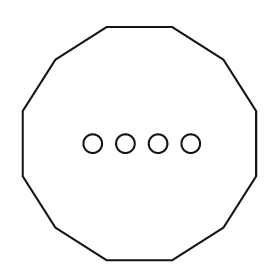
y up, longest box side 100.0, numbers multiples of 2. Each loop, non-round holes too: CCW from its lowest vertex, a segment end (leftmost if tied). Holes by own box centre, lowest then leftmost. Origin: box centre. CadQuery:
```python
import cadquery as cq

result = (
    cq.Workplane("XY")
    .moveTo(-14.0, -50.0)
    .lineTo(14.0, -50.0)
    .lineTo(36.0, -36.0)
    .lineTo(50.0, -14.0)
    .lineTo(50.0, 14.0)
    .lineTo(36.0, 36.0)
    .lineTo(14.0, 50.0)
    .lineTo(-14.0, 50.0)
    .lineTo(-36.0, 36.0)
    .lineTo(-50.0, 14.0)
    .lineTo(-50.0, -14.0)
    .lineTo(-36.0, -36.0)
    .close()
    .moveTo(-20.0, 0.0)
    .circle(4.0)
    .moveTo(-6.0, 0.0)
    .circle(4.0)
    .moveTo(8.0, 0.0)
    .circle(4.0)
    .moveTo(22.0, 0.0)
    .circle(4.0)
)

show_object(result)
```